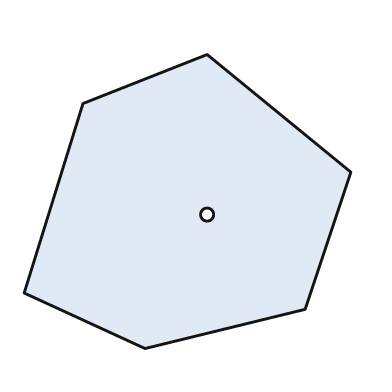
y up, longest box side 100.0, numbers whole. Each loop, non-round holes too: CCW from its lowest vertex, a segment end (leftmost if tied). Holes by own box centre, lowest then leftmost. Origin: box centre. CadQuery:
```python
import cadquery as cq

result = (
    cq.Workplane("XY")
    .moveTo(-13.0, -45.0)
    .lineTo(36.0, -33.0)
    .lineTo(50.0, 9.0)
    .lineTo(6.0, 45.0)
    .lineTo(-32.0, 30.0)
    .lineTo(-50.0, -28.0)
    .close()
    .moveTo(6.0, -4.0)
    .circle(2.0)
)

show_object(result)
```